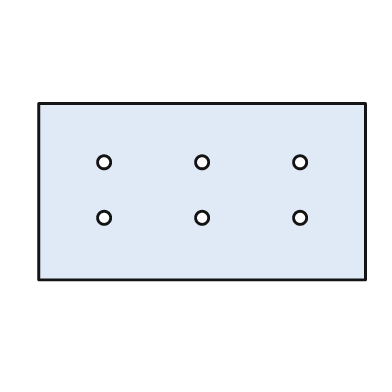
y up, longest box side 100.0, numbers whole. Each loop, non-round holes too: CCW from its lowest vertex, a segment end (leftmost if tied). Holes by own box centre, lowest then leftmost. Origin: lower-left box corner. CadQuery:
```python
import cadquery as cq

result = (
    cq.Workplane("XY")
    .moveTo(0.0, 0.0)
    .lineTo(100.0, 0.0)
    .lineTo(100.0, 54.0)
    .lineTo(0.0, 54.0)
    .close()
    .moveTo(20.0, 19.0)
    .circle(2.0)
    .moveTo(50.0, 19.0)
    .circle(2.0)
    .moveTo(80.0, 19.0)
    .circle(2.0)
    .moveTo(20.0, 36.0)
    .circle(2.0)
    .moveTo(50.0, 36.0)
    .circle(2.0)
    .moveTo(80.0, 36.0)
    .circle(2.0)
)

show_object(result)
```